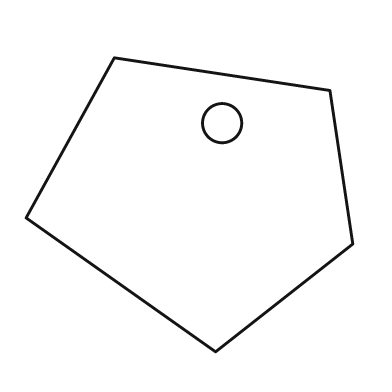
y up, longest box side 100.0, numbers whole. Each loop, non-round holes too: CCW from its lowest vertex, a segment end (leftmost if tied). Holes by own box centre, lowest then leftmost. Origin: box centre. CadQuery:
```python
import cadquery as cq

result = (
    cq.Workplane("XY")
    .moveTo(8.0, -45.0)
    .lineTo(50.0, -12.0)
    .lineTo(43.0, 35.0)
    .lineTo(-23.0, 45.0)
    .lineTo(-50.0, -4.0)
    .close()
    .moveTo(10.0, 25.0)
    .circle(6.0)
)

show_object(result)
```